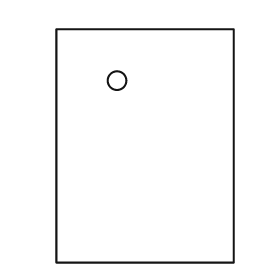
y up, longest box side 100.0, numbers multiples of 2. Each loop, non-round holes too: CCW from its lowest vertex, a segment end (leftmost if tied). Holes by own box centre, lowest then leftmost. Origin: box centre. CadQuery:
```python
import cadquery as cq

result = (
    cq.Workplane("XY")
    .moveTo(-38.0, -50.0)
    .lineTo(38.0, -50.0)
    .lineTo(38.0, 50.0)
    .lineTo(-38.0, 50.0)
    .close()
    .moveTo(-12.0, 28.0)
    .circle(4.0)
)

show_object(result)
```